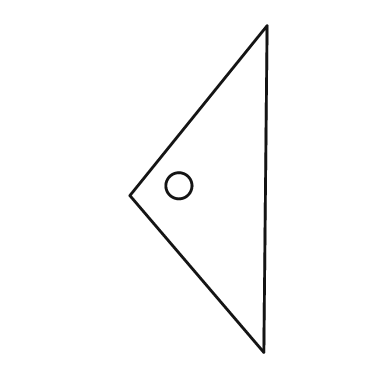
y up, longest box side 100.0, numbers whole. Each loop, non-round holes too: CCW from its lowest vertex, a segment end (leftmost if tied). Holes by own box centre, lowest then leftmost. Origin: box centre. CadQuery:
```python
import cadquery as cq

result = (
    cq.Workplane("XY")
    .moveTo(20.0, -50.0)
    .lineTo(21.0, 50.0)
    .lineTo(-21.0, -2.0)
    .close()
    .moveTo(-6.0, 1.0)
    .circle(4.0)
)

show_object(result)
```